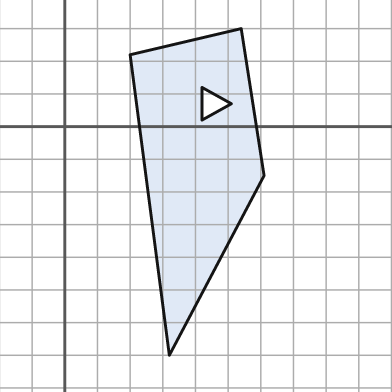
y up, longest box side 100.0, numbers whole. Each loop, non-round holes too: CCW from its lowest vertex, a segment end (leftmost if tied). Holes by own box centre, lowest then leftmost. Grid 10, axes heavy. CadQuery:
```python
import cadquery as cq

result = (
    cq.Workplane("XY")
    .moveTo(32.0, -70.0)
    .lineTo(61.0, -15.0)
    .lineTo(54.0, 30.0)
    .lineTo(20.0, 22.0)
    .close()
    .moveTo(42.0, 2.0)
    .lineTo(51.0, 7.0)
    .lineTo(42.0, 12.0)
    .close()
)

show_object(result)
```